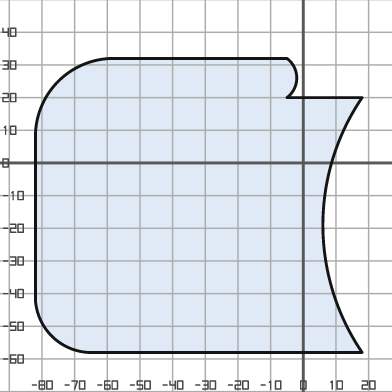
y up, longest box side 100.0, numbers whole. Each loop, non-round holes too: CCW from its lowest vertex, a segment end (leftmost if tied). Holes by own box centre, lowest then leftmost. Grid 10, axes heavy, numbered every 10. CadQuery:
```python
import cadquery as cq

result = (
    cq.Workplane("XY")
    .moveTo(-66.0, -58.0)
    .lineTo(18.0, -58.0)
    .threePointArc((6.0, -19.0), (18.0, 20.0))
    .lineTo(-5.0, 20.0)
    .threePointArc((-2.0, 26.0), (-5.0, 32.0))
    .lineTo(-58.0, 32.0)
    .threePointArc((-75.0, 25.0), (-82.0, 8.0))
    .lineTo(-82.0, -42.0)
    .threePointArc((-77.0, -53.0), (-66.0, -58.0))
    .close()
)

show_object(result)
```